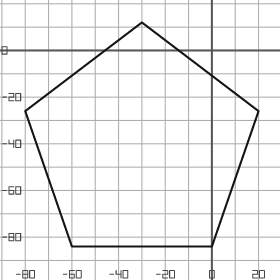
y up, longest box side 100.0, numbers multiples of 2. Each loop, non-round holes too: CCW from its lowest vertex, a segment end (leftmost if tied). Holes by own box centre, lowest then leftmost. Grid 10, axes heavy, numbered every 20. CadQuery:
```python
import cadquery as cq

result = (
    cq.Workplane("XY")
    .moveTo(-60.0, -84.0)
    .lineTo(0.0, -84.0)
    .lineTo(20.0, -26.0)
    .lineTo(-30.0, 12.0)
    .lineTo(-80.0, -26.0)
    .close()
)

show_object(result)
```